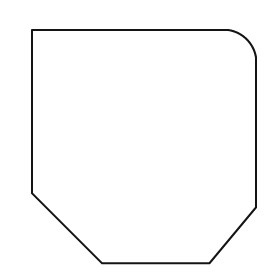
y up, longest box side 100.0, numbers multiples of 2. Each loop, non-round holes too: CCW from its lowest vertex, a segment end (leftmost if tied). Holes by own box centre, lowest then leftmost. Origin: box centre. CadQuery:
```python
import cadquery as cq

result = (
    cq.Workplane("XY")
    .moveTo(-18.0, -50.0)
    .lineTo(28.0, -50.0)
    .lineTo(48.0, -26.0)
    .lineTo(48.0, 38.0)
    .threePointArc((44.0, 46.0), (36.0, 50.0))
    .lineTo(-48.0, 50.0)
    .lineTo(-48.0, -20.0)
    .close()
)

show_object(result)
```